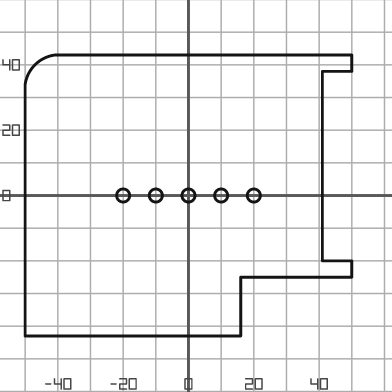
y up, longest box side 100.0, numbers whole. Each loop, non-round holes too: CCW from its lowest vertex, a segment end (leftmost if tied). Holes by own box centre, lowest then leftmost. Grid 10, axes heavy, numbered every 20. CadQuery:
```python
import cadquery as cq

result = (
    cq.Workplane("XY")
    .moveTo(-50.0, -43.0)
    .lineTo(16.0, -43.0)
    .lineTo(16.0, -25.0)
    .lineTo(50.0, -25.0)
    .lineTo(50.0, -20.0)
    .lineTo(41.0, -20.0)
    .lineTo(41.0, 38.0)
    .lineTo(50.0, 38.0)
    .lineTo(50.0, 43.0)
    .lineTo(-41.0, 43.0)
    .threePointArc((-47.0, 40.0), (-50.0, 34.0))
    .close()
    .moveTo(-20.0, 0.0)
    .circle(2.0)
    .moveTo(-10.0, 0.0)
    .circle(2.0)
    .moveTo(0.0, 0.0)
    .circle(2.0)
    .moveTo(10.0, 0.0)
    .circle(2.0)
    .moveTo(20.0, 0.0)
    .circle(2.0)
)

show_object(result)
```